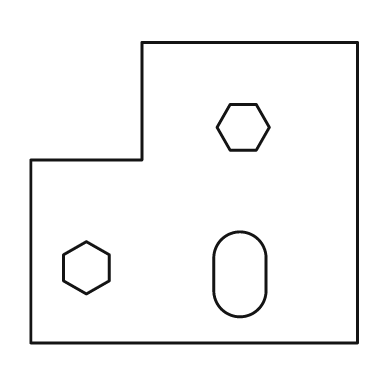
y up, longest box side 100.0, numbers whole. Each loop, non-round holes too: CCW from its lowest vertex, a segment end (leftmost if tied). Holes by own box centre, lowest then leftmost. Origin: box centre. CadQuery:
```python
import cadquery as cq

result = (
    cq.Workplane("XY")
    .moveTo(-50.0, -46.0)
    .lineTo(50.0, -46.0)
    .lineTo(50.0, 46.0)
    .lineTo(-16.0, 46.0)
    .lineTo(-16.0, 10.0)
    .lineTo(-50.0, 10.0)
    .close()
    .moveTo(6.0, -30.0)
    .threePointArc((14.0, -38.0), (22.0, -30.0))
    .lineTo(22.0, -20.0)
    .threePointArc((14.0, -12.0), (6.0, -20.0))
    .close()
    .moveTo(-33.0, -31.0)
    .lineTo(-26.0, -27.0)
    .lineTo(-26.0, -19.0)
    .lineTo(-33.0, -15.0)
    .lineTo(-40.0, -19.0)
    .lineTo(-40.0, -27.0)
    .close()
    .moveTo(11.0, 13.0)
    .lineTo(19.0, 13.0)
    .lineTo(23.0, 20.0)
    .lineTo(19.0, 27.0)
    .lineTo(11.0, 27.0)
    .lineTo(7.0, 20.0)
    .close()
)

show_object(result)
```